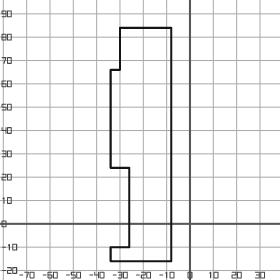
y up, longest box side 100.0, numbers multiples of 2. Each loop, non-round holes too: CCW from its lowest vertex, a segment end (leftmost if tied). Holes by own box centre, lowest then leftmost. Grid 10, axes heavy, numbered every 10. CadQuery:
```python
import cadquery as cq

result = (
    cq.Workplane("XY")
    .moveTo(-34.0, -16.0)
    .lineTo(-8.0, -16.0)
    .lineTo(-8.0, 84.0)
    .lineTo(-30.0, 84.0)
    .lineTo(-30.0, 66.0)
    .lineTo(-34.0, 66.0)
    .lineTo(-34.0, 24.0)
    .lineTo(-26.0, 24.0)
    .lineTo(-26.0, -10.0)
    .lineTo(-34.0, -10.0)
    .close()
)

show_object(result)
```